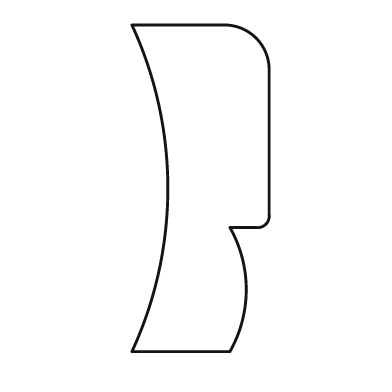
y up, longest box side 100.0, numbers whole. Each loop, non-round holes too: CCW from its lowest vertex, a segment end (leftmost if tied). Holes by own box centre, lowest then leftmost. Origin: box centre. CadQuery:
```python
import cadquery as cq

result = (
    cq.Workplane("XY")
    .moveTo(-21.0, -50.0)
    .lineTo(9.0, -50.0)
    .threePointArc((14.0, -31.0), (9.0, -12.0))
    .lineTo(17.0, -12.0)
    .threePointArc((20.0, -11.0), (21.0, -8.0))
    .lineTo(21.0, 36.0)
    .threePointArc((17.0, 46.0), (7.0, 50.0))
    .lineTo(-21.0, 50.0)
    .threePointArc((-10.0, 0.0), (-21.0, -50.0))
    .close()
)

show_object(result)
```